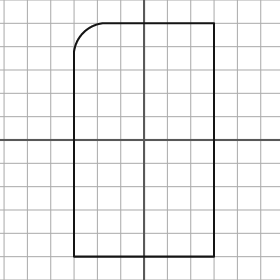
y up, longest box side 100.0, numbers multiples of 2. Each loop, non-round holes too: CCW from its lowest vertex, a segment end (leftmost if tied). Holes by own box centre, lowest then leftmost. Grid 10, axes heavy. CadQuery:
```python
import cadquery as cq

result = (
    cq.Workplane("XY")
    .moveTo(-30.0, -50.0)
    .lineTo(30.0, -50.0)
    .lineTo(30.0, 50.0)
    .lineTo(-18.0, 50.0)
    .threePointArc((-26.0, 46.0), (-30.0, 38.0))
    .close()
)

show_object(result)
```